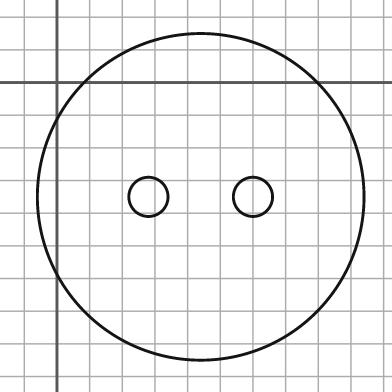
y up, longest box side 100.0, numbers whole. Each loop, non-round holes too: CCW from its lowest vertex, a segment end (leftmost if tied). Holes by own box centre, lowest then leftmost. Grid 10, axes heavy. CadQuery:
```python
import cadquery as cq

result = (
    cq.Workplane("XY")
    .moveTo(44.0, -35.0)
    .circle(50.0)
    .moveTo(28.0, -35.0)
    .circle(6.0)
    .moveTo(60.0, -35.0)
    .circle(6.0)
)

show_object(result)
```